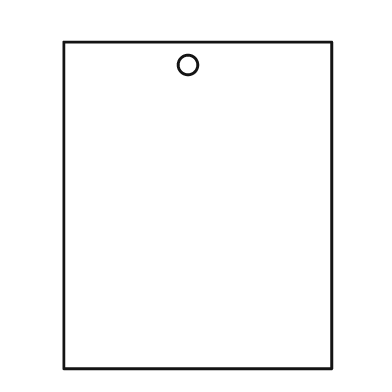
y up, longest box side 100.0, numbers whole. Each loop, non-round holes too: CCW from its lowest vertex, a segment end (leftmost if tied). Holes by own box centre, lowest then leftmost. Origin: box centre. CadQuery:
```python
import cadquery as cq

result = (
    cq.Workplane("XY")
    .moveTo(-41.0, -50.0)
    .lineTo(41.0, -50.0)
    .lineTo(41.0, 50.0)
    .lineTo(-41.0, 50.0)
    .close()
    .moveTo(-3.0, 43.0)
    .circle(3.0)
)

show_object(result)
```